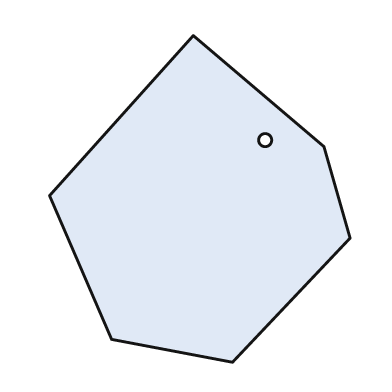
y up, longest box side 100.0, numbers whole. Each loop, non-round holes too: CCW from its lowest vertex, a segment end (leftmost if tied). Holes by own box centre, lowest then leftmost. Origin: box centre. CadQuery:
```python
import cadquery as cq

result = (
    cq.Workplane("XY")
    .moveTo(10.0, -50.0)
    .lineTo(46.0, -12.0)
    .lineTo(38.0, 16.0)
    .lineTo(-2.0, 50.0)
    .lineTo(-46.0, 1.0)
    .lineTo(-27.0, -43.0)
    .close()
    .moveTo(20.0, 18.0)
    .circle(2.0)
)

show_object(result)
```